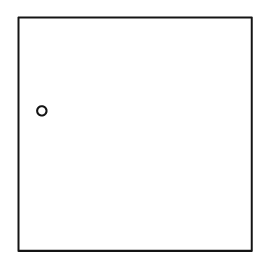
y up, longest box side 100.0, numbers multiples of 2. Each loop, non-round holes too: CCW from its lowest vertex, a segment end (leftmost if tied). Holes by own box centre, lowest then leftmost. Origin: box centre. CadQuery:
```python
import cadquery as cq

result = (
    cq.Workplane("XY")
    .moveTo(-50.0, -50.0)
    .lineTo(50.0, -50.0)
    .lineTo(50.0, 50.0)
    .lineTo(-50.0, 50.0)
    .close()
    .moveTo(-40.0, 10.0)
    .circle(2.0)
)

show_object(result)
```